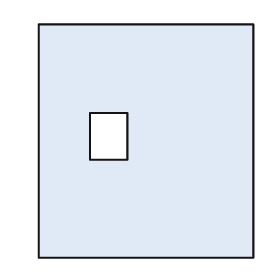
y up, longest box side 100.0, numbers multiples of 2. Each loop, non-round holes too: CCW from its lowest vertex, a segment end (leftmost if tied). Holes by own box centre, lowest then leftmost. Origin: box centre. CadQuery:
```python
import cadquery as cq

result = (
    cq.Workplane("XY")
    .moveTo(-46.0, -50.0)
    .lineTo(46.0, -50.0)
    .lineTo(46.0, 50.0)
    .lineTo(-46.0, 50.0)
    .close()
    .moveTo(-24.0, -8.0)
    .lineTo(-8.0, -8.0)
    .lineTo(-8.0, 12.0)
    .lineTo(-24.0, 12.0)
    .close()
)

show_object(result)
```